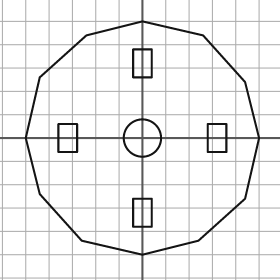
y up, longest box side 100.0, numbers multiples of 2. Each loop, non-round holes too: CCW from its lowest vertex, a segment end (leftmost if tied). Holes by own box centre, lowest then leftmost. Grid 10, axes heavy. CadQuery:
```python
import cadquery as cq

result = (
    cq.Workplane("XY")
    .moveTo(0.0, -50.0)
    .lineTo(24.0, -44.0)
    .lineTo(44.0, -26.0)
    .lineTo(50.0, 0.0)
    .lineTo(44.0, 24.0)
    .lineTo(26.0, 44.0)
    .lineTo(0.0, 50.0)
    .lineTo(-24.0, 44.0)
    .lineTo(-44.0, 26.0)
    .lineTo(-50.0, 0.0)
    .lineTo(-44.0, -24.0)
    .lineTo(-26.0, -44.0)
    .close()
    .moveTo(-4.0, -38.0)
    .lineTo(4.0, -38.0)
    .lineTo(4.0, -26.0)
    .lineTo(-4.0, -26.0)
    .close()
    .moveTo(-36.0, -6.0)
    .lineTo(-28.0, -6.0)
    .lineTo(-28.0, 6.0)
    .lineTo(-36.0, 6.0)
    .close()
    .moveTo(0.0, 0.0)
    .circle(8.0)
    .moveTo(28.0, -6.0)
    .lineTo(36.0, -6.0)
    .lineTo(36.0, 6.0)
    .lineTo(28.0, 6.0)
    .close()
    .moveTo(-4.0, 26.0)
    .lineTo(4.0, 26.0)
    .lineTo(4.0, 38.0)
    .lineTo(-4.0, 38.0)
    .close()
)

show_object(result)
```